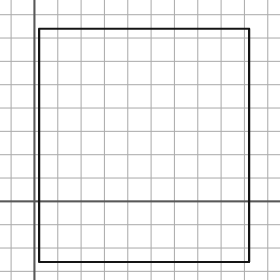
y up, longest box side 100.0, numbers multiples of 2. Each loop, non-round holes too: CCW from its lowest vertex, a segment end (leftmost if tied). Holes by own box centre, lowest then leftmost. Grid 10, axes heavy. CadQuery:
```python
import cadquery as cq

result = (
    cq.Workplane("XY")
    .moveTo(2.0, -26.0)
    .lineTo(92.0, -26.0)
    .lineTo(92.0, 74.0)
    .lineTo(2.0, 74.0)
    .close()
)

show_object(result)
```